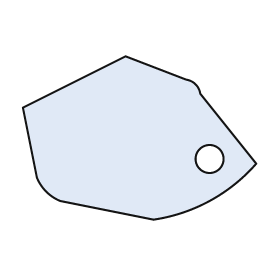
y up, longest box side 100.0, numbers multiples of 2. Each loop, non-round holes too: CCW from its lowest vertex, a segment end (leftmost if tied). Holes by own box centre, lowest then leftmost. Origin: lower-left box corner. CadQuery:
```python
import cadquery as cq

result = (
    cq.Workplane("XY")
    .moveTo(56.0, 0.0)
    .threePointArc((80.0, 8.0), (100.0, 24.0))
    .lineTo(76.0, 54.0)
    .threePointArc((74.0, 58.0), (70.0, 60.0))
    .lineTo(44.0, 70.0)
    .lineTo(0.0, 48.0)
    .lineTo(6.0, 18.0)
    .threePointArc((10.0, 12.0), (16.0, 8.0))
    .close()
    .moveTo(80.0, 26.0)
    .circle(6.0)
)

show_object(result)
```